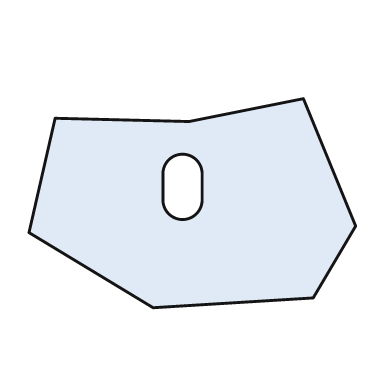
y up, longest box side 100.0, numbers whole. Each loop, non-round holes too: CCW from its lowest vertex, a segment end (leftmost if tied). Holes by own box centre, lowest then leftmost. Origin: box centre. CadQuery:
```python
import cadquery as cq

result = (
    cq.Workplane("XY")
    .moveTo(-12.0, -32.0)
    .lineTo(37.0, -29.0)
    .lineTo(50.0, -7.0)
    .lineTo(34.0, 32.0)
    .lineTo(-1.0, 25.0)
    .lineTo(-42.0, 26.0)
    .lineTo(-50.0, -9.0)
    .close()
    .moveTo(-9.0, 1.0)
    .threePointArc((-3.0, -5.0), (3.0, 1.0))
    .lineTo(3.0, 9.0)
    .threePointArc((-3.0, 15.0), (-9.0, 9.0))
    .close()
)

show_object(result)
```